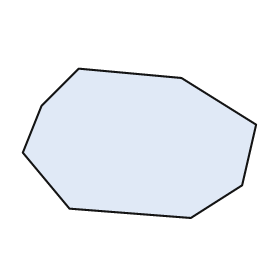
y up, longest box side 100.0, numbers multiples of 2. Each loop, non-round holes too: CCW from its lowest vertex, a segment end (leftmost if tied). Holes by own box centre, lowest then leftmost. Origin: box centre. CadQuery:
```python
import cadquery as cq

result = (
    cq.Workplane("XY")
    .moveTo(22.0, -32.0)
    .lineTo(44.0, -18.0)
    .lineTo(50.0, 8.0)
    .lineTo(18.0, 28.0)
    .lineTo(-26.0, 32.0)
    .lineTo(-42.0, 16.0)
    .lineTo(-50.0, -4.0)
    .lineTo(-30.0, -28.0)
    .close()
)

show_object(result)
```